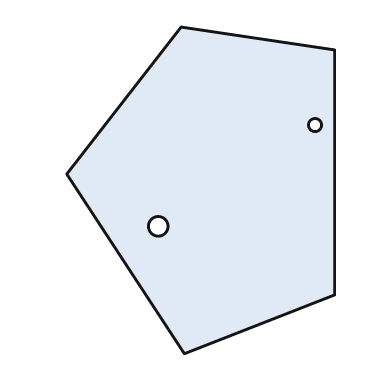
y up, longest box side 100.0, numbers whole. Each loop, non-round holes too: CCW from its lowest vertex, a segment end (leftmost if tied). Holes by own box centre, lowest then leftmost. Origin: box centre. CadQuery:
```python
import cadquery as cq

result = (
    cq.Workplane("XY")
    .moveTo(-5.0, -50.0)
    .lineTo(41.0, -32.0)
    .lineTo(41.0, 43.0)
    .lineTo(-6.0, 50.0)
    .lineTo(-41.0, 5.0)
    .close()
    .moveTo(-13.0, -11.0)
    .circle(3.0)
    .moveTo(35.0, 20.0)
    .circle(2.0)
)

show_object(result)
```